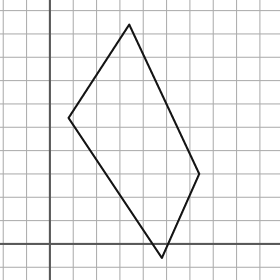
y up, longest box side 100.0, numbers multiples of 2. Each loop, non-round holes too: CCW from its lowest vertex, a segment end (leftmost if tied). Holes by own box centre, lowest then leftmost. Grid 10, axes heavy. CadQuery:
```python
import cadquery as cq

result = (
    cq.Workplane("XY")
    .moveTo(48.0, -6.0)
    .lineTo(64.0, 30.0)
    .lineTo(34.0, 94.0)
    .lineTo(8.0, 54.0)
    .close()
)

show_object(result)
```